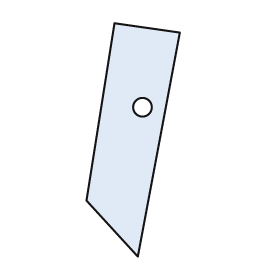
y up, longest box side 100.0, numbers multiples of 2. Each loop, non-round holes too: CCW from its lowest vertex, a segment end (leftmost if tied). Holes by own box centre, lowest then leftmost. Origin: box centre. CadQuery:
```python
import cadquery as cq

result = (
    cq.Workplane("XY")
    .moveTo(2.0, -50.0)
    .lineTo(20.0, 46.0)
    .lineTo(-8.0, 50.0)
    .lineTo(-20.0, -26.0)
    .close()
    .moveTo(4.0, 14.0)
    .circle(4.0)
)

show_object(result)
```